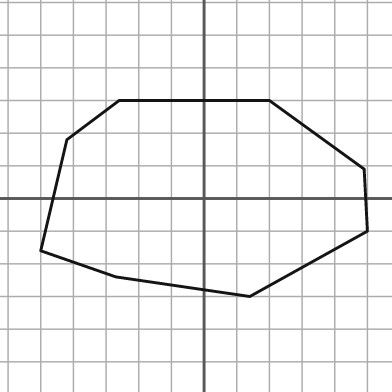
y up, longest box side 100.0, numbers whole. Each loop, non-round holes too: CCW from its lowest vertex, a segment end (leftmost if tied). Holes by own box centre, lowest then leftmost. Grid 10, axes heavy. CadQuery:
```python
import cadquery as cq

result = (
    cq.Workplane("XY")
    .moveTo(14.0, -30.0)
    .lineTo(50.0, -10.0)
    .lineTo(49.0, 9.0)
    .lineTo(20.0, 30.0)
    .lineTo(-26.0, 30.0)
    .lineTo(-42.0, 18.0)
    .lineTo(-50.0, -16.0)
    .lineTo(-27.0, -24.0)
    .close()
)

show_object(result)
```